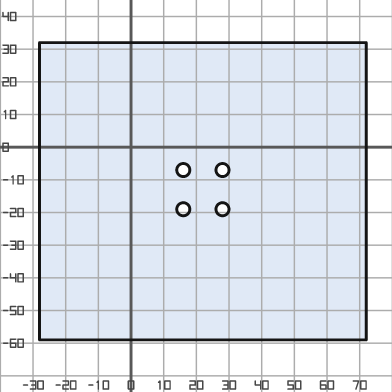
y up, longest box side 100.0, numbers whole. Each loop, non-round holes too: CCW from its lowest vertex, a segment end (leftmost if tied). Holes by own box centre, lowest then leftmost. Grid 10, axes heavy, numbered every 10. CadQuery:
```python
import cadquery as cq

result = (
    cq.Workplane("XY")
    .moveTo(-28.0, -59.0)
    .lineTo(72.0, -59.0)
    .lineTo(72.0, 32.0)
    .lineTo(-28.0, 32.0)
    .close()
    .moveTo(16.0, -19.0)
    .circle(2.0)
    .moveTo(28.0, -19.0)
    .circle(2.0)
    .moveTo(16.0, -7.0)
    .circle(2.0)
    .moveTo(28.0, -7.0)
    .circle(2.0)
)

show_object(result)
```